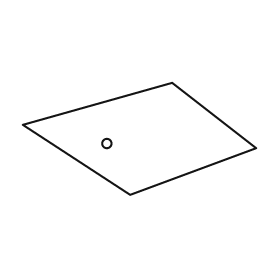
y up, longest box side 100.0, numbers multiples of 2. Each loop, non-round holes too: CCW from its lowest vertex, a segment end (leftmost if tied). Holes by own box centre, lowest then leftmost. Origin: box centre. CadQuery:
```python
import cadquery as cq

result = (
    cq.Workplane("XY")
    .moveTo(-4.0, -24.0)
    .lineTo(50.0, -4.0)
    .lineTo(14.0, 24.0)
    .lineTo(-50.0, 6.0)
    .close()
    .moveTo(-14.0, -2.0)
    .circle(2.0)
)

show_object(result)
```